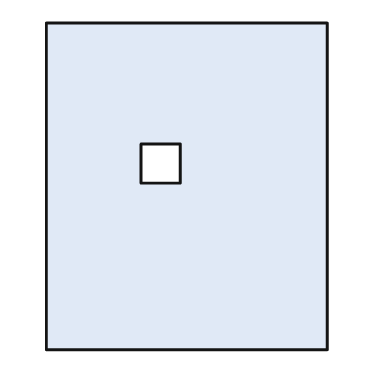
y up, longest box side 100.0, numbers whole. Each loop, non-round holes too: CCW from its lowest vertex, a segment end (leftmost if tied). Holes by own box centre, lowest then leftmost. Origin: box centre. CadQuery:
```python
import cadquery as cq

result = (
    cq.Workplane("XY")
    .moveTo(-43.0, -50.0)
    .lineTo(43.0, -50.0)
    .lineTo(43.0, 50.0)
    .lineTo(-43.0, 50.0)
    .close()
    .moveTo(-14.0, 1.0)
    .lineTo(-2.0, 1.0)
    .lineTo(-2.0, 13.0)
    .lineTo(-14.0, 13.0)
    .close()
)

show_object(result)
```